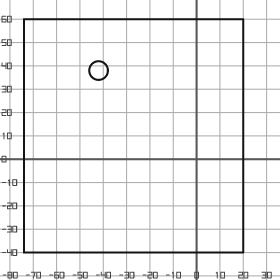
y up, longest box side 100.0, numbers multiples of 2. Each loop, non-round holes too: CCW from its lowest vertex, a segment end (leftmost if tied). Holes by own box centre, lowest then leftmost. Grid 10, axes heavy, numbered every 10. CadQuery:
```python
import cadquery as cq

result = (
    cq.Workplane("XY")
    .moveTo(-74.0, -40.0)
    .lineTo(20.0, -40.0)
    .lineTo(20.0, 60.0)
    .lineTo(-74.0, 60.0)
    .close()
    .moveTo(-42.0, 38.0)
    .circle(4.0)
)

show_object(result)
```